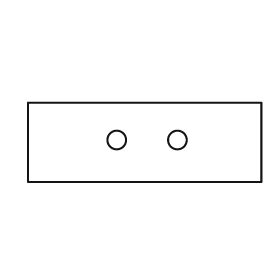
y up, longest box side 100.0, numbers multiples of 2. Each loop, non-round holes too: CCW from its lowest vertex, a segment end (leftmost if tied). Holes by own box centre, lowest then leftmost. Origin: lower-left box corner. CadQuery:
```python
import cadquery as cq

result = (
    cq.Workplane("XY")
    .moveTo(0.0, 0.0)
    .lineTo(100.0, 0.0)
    .lineTo(100.0, 34.0)
    .lineTo(0.0, 34.0)
    .close()
    .moveTo(38.0, 18.0)
    .circle(4.0)
    .moveTo(64.0, 18.0)
    .circle(4.0)
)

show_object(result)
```